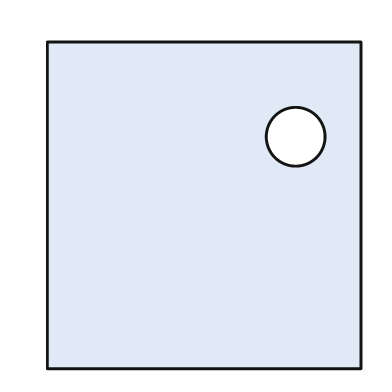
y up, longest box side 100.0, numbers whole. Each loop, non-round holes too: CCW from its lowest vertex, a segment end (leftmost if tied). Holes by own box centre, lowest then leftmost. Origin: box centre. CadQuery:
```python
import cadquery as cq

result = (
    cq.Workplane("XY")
    .moveTo(-48.0, -50.0)
    .lineTo(48.0, -50.0)
    .lineTo(48.0, 50.0)
    .lineTo(-48.0, 50.0)
    .close()
    .moveTo(28.0, 21.0)
    .circle(9.0)
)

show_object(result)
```